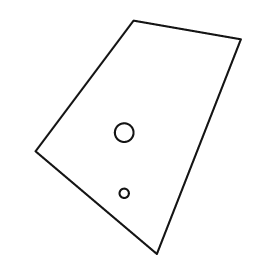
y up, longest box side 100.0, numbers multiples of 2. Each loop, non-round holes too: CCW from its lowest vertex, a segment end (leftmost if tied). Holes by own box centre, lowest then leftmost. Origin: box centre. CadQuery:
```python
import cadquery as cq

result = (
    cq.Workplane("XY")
    .moveTo(8.0, -50.0)
    .lineTo(44.0, 42.0)
    .lineTo(-2.0, 50.0)
    .lineTo(-44.0, -6.0)
    .close()
    .moveTo(-6.0, -24.0)
    .circle(2.0)
    .moveTo(-6.0, 2.0)
    .circle(4.0)
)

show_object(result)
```